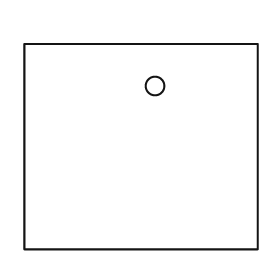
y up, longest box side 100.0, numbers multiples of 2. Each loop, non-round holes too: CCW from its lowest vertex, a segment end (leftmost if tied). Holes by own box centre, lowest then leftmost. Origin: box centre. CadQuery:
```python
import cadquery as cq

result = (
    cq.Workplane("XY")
    .moveTo(-50.0, -44.0)
    .lineTo(50.0, -44.0)
    .lineTo(50.0, 44.0)
    .lineTo(-50.0, 44.0)
    .close()
    .moveTo(6.0, 26.0)
    .circle(4.0)
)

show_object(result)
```